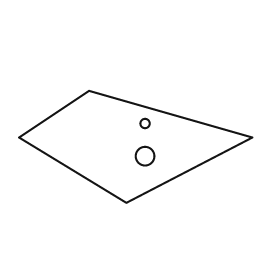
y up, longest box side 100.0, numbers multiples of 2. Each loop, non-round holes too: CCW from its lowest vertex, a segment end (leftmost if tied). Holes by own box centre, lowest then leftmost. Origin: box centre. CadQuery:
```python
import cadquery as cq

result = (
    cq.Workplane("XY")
    .moveTo(-4.0, -24.0)
    .lineTo(50.0, 4.0)
    .lineTo(-20.0, 24.0)
    .lineTo(-50.0, 4.0)
    .close()
    .moveTo(4.0, -4.0)
    .circle(4.0)
    .moveTo(4.0, 10.0)
    .circle(2.0)
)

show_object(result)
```